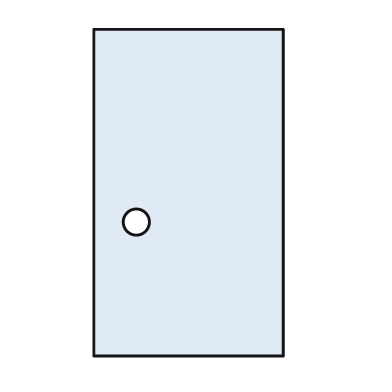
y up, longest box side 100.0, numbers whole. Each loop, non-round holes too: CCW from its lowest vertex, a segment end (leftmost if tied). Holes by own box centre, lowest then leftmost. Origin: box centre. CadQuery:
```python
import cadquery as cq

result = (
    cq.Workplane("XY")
    .moveTo(-29.0, -50.0)
    .lineTo(29.0, -50.0)
    .lineTo(29.0, 50.0)
    .lineTo(-29.0, 50.0)
    .close()
    .moveTo(-16.0, -9.0)
    .circle(4.0)
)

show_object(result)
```